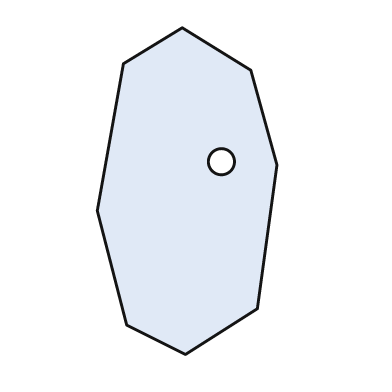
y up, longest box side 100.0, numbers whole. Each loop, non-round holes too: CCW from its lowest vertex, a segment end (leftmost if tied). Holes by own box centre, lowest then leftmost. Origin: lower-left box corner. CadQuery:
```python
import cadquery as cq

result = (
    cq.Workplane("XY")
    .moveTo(27.0, 0.0)
    .lineTo(49.0, 14.0)
    .lineTo(55.0, 58.0)
    .lineTo(47.0, 87.0)
    .lineTo(26.0, 100.0)
    .lineTo(8.0, 89.0)
    .lineTo(0.0, 44.0)
    .lineTo(9.0, 9.0)
    .close()
    .moveTo(38.0, 59.0)
    .circle(4.0)
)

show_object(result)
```